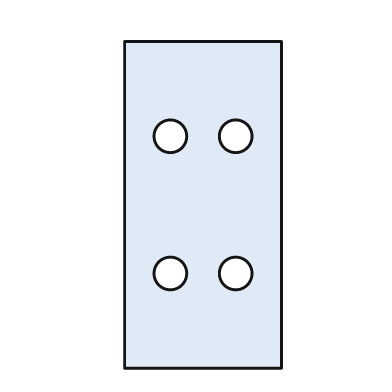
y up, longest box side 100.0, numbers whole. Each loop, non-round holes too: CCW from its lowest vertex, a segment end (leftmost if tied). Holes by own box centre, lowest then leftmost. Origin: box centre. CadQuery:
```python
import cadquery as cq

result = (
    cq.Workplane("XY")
    .moveTo(-24.0, -50.0)
    .lineTo(24.0, -50.0)
    .lineTo(24.0, 50.0)
    .lineTo(-24.0, 50.0)
    .close()
    .moveTo(-10.0, -21.0)
    .circle(5.0)
    .moveTo(10.0, -21.0)
    .circle(5.0)
    .moveTo(-10.0, 21.0)
    .circle(5.0)
    .moveTo(10.0, 21.0)
    .circle(5.0)
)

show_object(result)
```